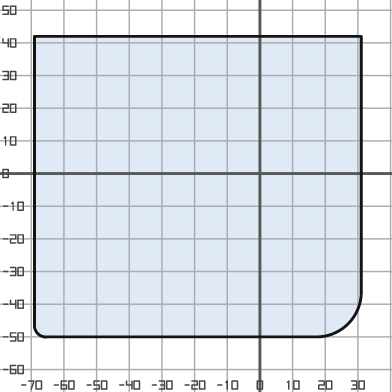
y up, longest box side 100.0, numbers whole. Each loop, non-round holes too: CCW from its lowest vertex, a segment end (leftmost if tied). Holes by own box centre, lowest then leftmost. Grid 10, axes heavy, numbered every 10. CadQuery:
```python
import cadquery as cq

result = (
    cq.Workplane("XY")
    .moveTo(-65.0, -50.0)
    .lineTo(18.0, -50.0)
    .threePointArc((27.0, -46.0), (31.0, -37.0))
    .lineTo(31.0, 42.0)
    .lineTo(-69.0, 42.0)
    .lineTo(-69.0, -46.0)
    .threePointArc((-68.0, -49.0), (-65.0, -50.0))
    .close()
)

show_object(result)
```